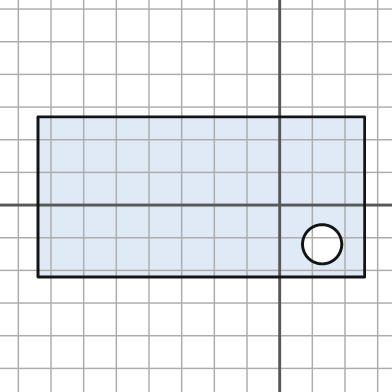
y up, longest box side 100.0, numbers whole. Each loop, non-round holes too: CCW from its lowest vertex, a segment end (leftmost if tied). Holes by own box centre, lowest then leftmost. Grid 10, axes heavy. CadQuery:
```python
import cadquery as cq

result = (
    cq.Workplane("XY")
    .moveTo(-74.0, -22.0)
    .lineTo(26.0, -22.0)
    .lineTo(26.0, 27.0)
    .lineTo(-74.0, 27.0)
    .close()
    .moveTo(13.0, -12.0)
    .circle(6.0)
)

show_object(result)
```